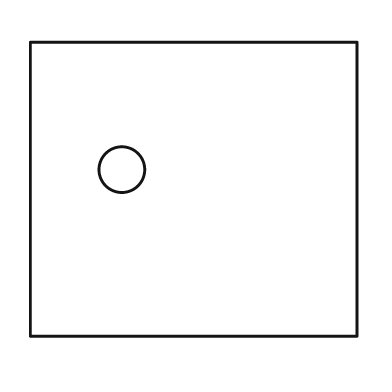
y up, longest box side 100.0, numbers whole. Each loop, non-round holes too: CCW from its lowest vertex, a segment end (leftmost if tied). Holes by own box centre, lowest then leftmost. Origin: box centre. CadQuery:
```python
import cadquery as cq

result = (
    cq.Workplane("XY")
    .moveTo(-50.0, -45.0)
    .lineTo(50.0, -45.0)
    .lineTo(50.0, 45.0)
    .lineTo(-50.0, 45.0)
    .close()
    .moveTo(-22.0, 6.0)
    .circle(7.0)
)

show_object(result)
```